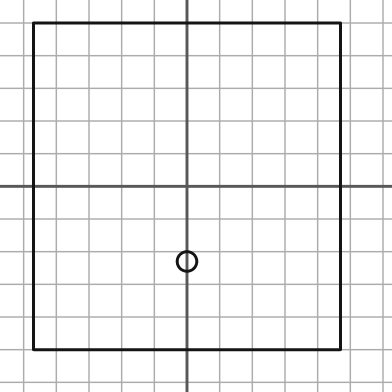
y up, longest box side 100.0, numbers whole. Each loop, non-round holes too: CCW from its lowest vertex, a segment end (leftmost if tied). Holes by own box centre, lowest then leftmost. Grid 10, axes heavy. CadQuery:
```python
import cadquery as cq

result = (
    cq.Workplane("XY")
    .moveTo(-47.0, -50.0)
    .lineTo(47.0, -50.0)
    .lineTo(47.0, 50.0)
    .lineTo(-47.0, 50.0)
    .close()
    .moveTo(0.0, -23.0)
    .circle(3.0)
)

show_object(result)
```